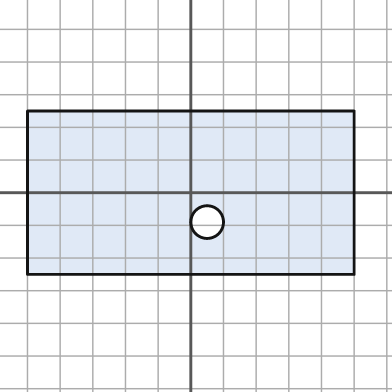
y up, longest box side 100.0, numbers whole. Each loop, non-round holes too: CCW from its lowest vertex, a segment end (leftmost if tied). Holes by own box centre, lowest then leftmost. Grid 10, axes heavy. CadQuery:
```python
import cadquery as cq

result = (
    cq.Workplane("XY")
    .moveTo(-50.0, -25.0)
    .lineTo(50.0, -25.0)
    .lineTo(50.0, 25.0)
    .lineTo(-50.0, 25.0)
    .close()
    .moveTo(5.0, -9.0)
    .circle(5.0)
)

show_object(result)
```